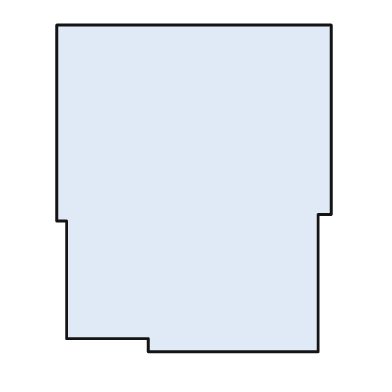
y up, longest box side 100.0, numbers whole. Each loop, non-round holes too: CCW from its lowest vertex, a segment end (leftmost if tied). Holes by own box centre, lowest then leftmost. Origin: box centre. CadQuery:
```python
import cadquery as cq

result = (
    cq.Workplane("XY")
    .moveTo(-14.0, -50.0)
    .lineTo(38.0, -50.0)
    .lineTo(38.0, -8.0)
    .lineTo(42.0, -8.0)
    .lineTo(42.0, 50.0)
    .lineTo(-42.0, 50.0)
    .lineTo(-42.0, -10.0)
    .lineTo(-39.0, -10.0)
    .lineTo(-39.0, -46.0)
    .lineTo(-14.0, -46.0)
    .close()
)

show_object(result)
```